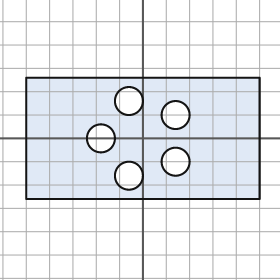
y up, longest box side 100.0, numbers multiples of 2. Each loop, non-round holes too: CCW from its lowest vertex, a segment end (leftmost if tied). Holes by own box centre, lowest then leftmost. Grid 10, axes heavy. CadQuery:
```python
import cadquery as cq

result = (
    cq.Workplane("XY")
    .moveTo(-50.0, -26.0)
    .lineTo(50.0, -26.0)
    .lineTo(50.0, 26.0)
    .lineTo(-50.0, 26.0)
    .close()
    .moveTo(-6.0, -16.0)
    .circle(6.0)
    .moveTo(14.0, -10.0)
    .circle(6.0)
    .moveTo(-18.0, 0.0)
    .circle(6.0)
    .moveTo(14.0, 10.0)
    .circle(6.0)
    .moveTo(-6.0, 16.0)
    .circle(6.0)
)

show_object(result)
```